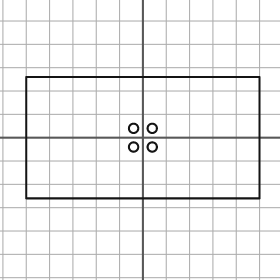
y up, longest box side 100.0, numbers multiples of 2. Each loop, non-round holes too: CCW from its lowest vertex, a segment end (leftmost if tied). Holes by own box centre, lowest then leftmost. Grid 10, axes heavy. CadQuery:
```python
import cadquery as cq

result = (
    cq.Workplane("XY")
    .moveTo(-50.0, -26.0)
    .lineTo(50.0, -26.0)
    .lineTo(50.0, 26.0)
    .lineTo(-50.0, 26.0)
    .close()
    .moveTo(-4.0, -4.0)
    .circle(2.0)
    .moveTo(4.0, -4.0)
    .circle(2.0)
    .moveTo(-4.0, 4.0)
    .circle(2.0)
    .moveTo(4.0, 4.0)
    .circle(2.0)
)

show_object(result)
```